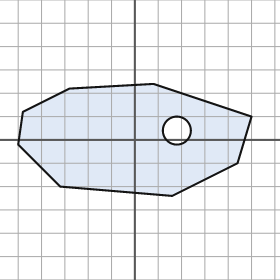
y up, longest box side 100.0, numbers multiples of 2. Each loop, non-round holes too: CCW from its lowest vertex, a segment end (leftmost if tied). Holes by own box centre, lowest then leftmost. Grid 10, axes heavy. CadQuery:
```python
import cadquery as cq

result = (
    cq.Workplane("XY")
    .moveTo(16.0, -24.0)
    .lineTo(44.0, -10.0)
    .lineTo(50.0, 10.0)
    .lineTo(8.0, 24.0)
    .lineTo(-28.0, 22.0)
    .lineTo(-48.0, 12.0)
    .lineTo(-50.0, -2.0)
    .lineTo(-32.0, -20.0)
    .close()
    .moveTo(18.0, 4.0)
    .circle(6.0)
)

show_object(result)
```